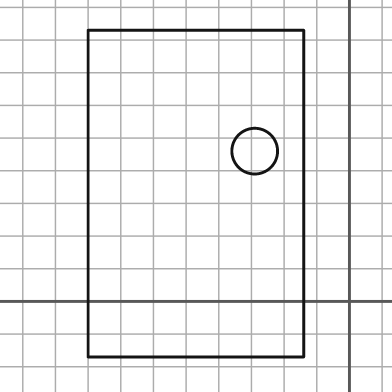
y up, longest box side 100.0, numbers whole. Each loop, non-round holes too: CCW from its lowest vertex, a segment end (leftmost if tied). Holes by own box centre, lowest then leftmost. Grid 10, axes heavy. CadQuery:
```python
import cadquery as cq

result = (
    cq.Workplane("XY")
    .moveTo(-80.0, -17.0)
    .lineTo(-14.0, -17.0)
    .lineTo(-14.0, 83.0)
    .lineTo(-80.0, 83.0)
    .close()
    .moveTo(-29.0, 46.0)
    .circle(7.0)
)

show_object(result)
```